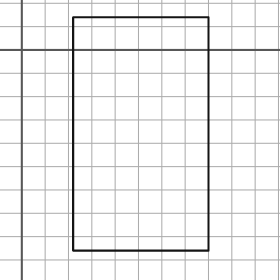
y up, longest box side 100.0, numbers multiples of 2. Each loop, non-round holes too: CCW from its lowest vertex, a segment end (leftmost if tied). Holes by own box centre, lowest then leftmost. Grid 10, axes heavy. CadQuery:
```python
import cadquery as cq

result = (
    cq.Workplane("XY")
    .moveTo(22.0, -86.0)
    .lineTo(80.0, -86.0)
    .lineTo(80.0, 14.0)
    .lineTo(22.0, 14.0)
    .close()
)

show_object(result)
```